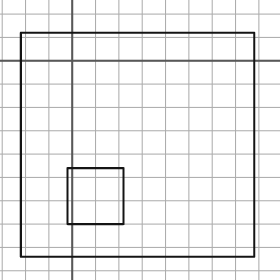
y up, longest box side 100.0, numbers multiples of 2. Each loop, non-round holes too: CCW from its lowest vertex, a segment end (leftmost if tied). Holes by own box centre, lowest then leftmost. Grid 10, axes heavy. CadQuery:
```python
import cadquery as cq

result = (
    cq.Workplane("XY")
    .moveTo(-22.0, -84.0)
    .lineTo(78.0, -84.0)
    .lineTo(78.0, 12.0)
    .lineTo(-22.0, 12.0)
    .close()
    .moveTo(-2.0, -70.0)
    .lineTo(22.0, -70.0)
    .lineTo(22.0, -46.0)
    .lineTo(-2.0, -46.0)
    .close()
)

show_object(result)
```